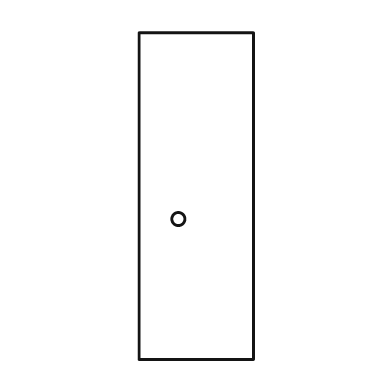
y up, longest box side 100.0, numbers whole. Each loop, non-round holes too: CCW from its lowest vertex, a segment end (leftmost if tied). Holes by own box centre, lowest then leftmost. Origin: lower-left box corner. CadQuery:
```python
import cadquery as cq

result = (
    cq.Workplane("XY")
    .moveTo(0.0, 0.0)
    .lineTo(35.0, 0.0)
    .lineTo(35.0, 100.0)
    .lineTo(0.0, 100.0)
    .close()
    .moveTo(12.0, 43.0)
    .circle(2.0)
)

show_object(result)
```